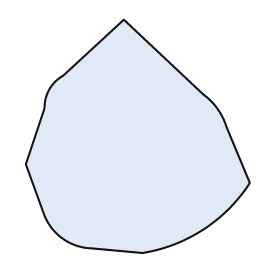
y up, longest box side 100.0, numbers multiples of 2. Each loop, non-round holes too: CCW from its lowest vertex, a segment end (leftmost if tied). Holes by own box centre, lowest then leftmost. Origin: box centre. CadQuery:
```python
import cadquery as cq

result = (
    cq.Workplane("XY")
    .moveTo(2.0, -50.0)
    .threePointArc((28.0, -40.0), (48.0, -20.0))
    .lineTo(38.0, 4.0)
    .threePointArc((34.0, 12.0), (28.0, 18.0))
    .lineTo(-6.0, 50.0)
    .lineTo(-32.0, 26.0)
    .threePointArc((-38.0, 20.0), (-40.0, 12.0))
    .lineTo(-48.0, -12.0)
    .lineTo(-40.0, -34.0)
    .threePointArc((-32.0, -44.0), (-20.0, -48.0))
    .close()
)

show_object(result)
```